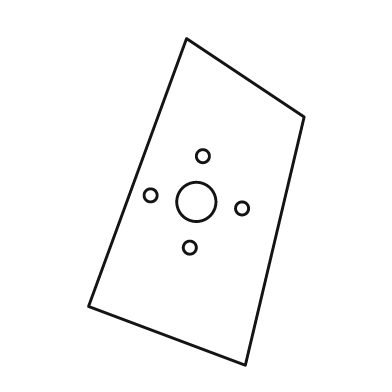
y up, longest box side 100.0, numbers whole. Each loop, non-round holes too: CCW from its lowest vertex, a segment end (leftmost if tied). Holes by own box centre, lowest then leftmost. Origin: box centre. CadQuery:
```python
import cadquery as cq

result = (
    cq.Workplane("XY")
    .moveTo(15.0, -50.0)
    .lineTo(33.0, 26.0)
    .lineTo(-3.0, 50.0)
    .lineTo(-33.0, -32.0)
    .close()
    .moveTo(-2.0, -14.0)
    .circle(2.0)
    .moveTo(14.0, -2.0)
    .circle(2.0)
    .moveTo(0.0, 0.0)
    .circle(6.0)
    .moveTo(-14.0, 2.0)
    .circle(2.0)
    .moveTo(2.0, 14.0)
    .circle(2.0)
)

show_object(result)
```